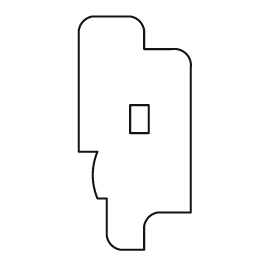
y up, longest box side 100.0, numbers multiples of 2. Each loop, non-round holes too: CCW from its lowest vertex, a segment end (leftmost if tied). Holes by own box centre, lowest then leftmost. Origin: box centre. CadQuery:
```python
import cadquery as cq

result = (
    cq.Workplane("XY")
    .moveTo(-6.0, -50.0)
    .lineTo(4.0, -50.0)
    .lineTo(4.0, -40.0)
    .threePointArc((6.0, -36.0), (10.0, -34.0))
    .lineTo(24.0, -34.0)
    .lineTo(24.0, 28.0)
    .threePointArc((22.0, 34.0), (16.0, 36.0))
    .lineTo(4.0, 36.0)
    .lineTo(4.0, 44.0)
    .threePointArc((2.0, 48.0), (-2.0, 50.0))
    .lineTo(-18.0, 50.0)
    .threePointArc((-22.0, 48.0), (-24.0, 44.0))
    .lineTo(-24.0, -8.0)
    .lineTo(-16.0, -8.0)
    .threePointArc((-18.0, -18.0), (-16.0, -28.0))
    .lineTo(-12.0, -28.0)
    .lineTo(-12.0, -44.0)
    .threePointArc((-10.0, -48.0), (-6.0, -50.0))
    .close()
    .moveTo(-2.0, 0.0)
    .lineTo(6.0, 0.0)
    .lineTo(6.0, 12.0)
    .lineTo(-2.0, 12.0)
    .close()
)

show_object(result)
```